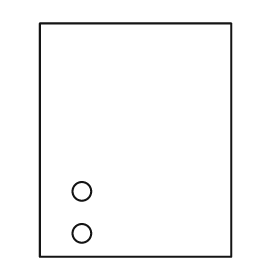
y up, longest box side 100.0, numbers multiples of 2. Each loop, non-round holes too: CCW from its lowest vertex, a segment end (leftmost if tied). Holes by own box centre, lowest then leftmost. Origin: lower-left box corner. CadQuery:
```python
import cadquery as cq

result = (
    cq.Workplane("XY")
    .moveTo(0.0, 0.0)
    .lineTo(82.0, 0.0)
    .lineTo(82.0, 100.0)
    .lineTo(0.0, 100.0)
    .close()
    .moveTo(18.0, 10.0)
    .circle(4.0)
    .moveTo(18.0, 28.0)
    .circle(4.0)
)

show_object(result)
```